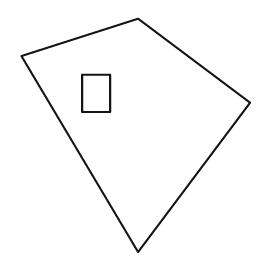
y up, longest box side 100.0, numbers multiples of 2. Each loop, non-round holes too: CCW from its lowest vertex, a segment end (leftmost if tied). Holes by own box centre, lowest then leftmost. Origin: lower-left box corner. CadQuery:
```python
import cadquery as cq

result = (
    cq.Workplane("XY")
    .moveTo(50.0, 0.0)
    .lineTo(98.0, 64.0)
    .lineTo(50.0, 100.0)
    .lineTo(0.0, 84.0)
    .close()
    .moveTo(26.0, 60.0)
    .lineTo(38.0, 60.0)
    .lineTo(38.0, 76.0)
    .lineTo(26.0, 76.0)
    .close()
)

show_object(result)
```